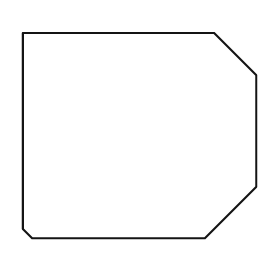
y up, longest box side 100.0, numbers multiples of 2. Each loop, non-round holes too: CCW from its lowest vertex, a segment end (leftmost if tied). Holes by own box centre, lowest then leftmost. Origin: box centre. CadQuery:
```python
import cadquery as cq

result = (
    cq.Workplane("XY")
    .moveTo(-46.0, -44.0)
    .lineTo(28.0, -44.0)
    .lineTo(50.0, -22.0)
    .lineTo(50.0, 26.0)
    .lineTo(32.0, 44.0)
    .lineTo(-50.0, 44.0)
    .lineTo(-50.0, -40.0)
    .close()
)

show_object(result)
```